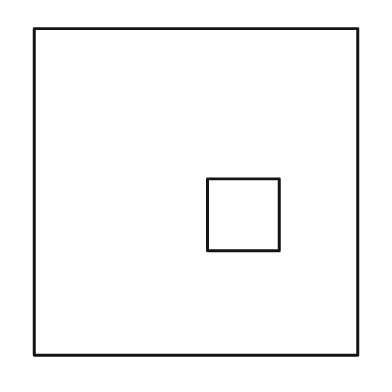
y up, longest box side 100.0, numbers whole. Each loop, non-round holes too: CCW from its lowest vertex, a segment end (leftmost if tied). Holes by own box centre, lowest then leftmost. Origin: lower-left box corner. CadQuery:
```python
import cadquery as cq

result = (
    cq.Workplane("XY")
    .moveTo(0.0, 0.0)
    .lineTo(99.0, 0.0)
    .lineTo(99.0, 100.0)
    .lineTo(0.0, 100.0)
    .close()
    .moveTo(53.0, 32.0)
    .lineTo(75.0, 32.0)
    .lineTo(75.0, 54.0)
    .lineTo(53.0, 54.0)
    .close()
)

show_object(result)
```